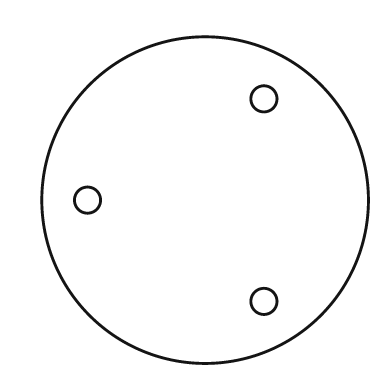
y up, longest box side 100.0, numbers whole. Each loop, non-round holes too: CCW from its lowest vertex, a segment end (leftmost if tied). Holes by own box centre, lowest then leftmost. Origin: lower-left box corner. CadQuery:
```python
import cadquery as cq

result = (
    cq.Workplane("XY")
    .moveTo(50.0, 50.0)
    .circle(50.0)
    .moveTo(68.0, 19.0)
    .circle(4.0)
    .moveTo(14.0, 50.0)
    .circle(4.0)
    .moveTo(68.0, 81.0)
    .circle(4.0)
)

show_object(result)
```